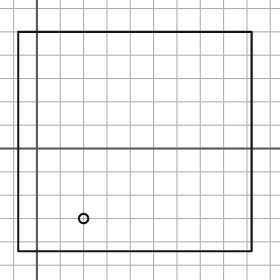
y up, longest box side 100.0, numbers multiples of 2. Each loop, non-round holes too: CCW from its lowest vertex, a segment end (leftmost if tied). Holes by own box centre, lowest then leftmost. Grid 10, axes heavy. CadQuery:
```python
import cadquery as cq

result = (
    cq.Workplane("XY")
    .moveTo(-8.0, -44.0)
    .lineTo(92.0, -44.0)
    .lineTo(92.0, 50.0)
    .lineTo(-8.0, 50.0)
    .close()
    .moveTo(20.0, -30.0)
    .circle(2.0)
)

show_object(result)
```